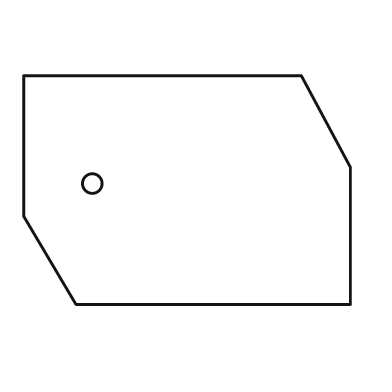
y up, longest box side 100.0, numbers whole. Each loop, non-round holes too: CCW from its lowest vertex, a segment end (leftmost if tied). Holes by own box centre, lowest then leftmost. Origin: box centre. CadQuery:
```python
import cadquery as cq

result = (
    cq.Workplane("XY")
    .moveTo(-34.0, -35.0)
    .lineTo(50.0, -35.0)
    .lineTo(50.0, 7.0)
    .lineTo(35.0, 35.0)
    .lineTo(-50.0, 35.0)
    .lineTo(-50.0, -8.0)
    .close()
    .moveTo(-29.0, 2.0)
    .circle(3.0)
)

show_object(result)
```